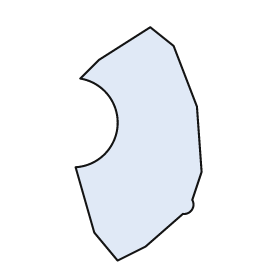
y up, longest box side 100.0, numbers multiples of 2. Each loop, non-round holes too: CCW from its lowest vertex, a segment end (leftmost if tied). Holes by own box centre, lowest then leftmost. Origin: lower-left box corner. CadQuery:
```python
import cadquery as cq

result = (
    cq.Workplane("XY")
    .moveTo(18.0, 0.0)
    .lineTo(30.0, 6.0)
    .lineTo(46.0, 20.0)
    .threePointArc((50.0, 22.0), (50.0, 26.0))
    .lineTo(54.0, 38.0)
    .lineTo(52.0, 66.0)
    .lineTo(42.0, 92.0)
    .lineTo(32.0, 100.0)
    .lineTo(10.0, 86.0)
    .lineTo(2.0, 78.0)
    .threePointArc((18.0, 58.0), (0.0, 40.0))
    .lineTo(8.0, 12.0)
    .close()
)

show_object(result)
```